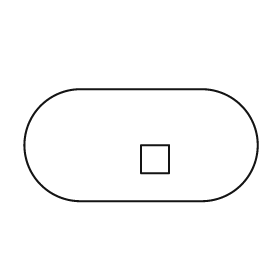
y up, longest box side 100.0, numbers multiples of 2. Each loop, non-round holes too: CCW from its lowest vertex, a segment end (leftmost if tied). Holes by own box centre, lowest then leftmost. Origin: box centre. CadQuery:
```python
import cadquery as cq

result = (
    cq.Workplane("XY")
    .moveTo(-26.0, -24.0)
    .lineTo(26.0, -24.0)
    .threePointArc((50.0, 0.0), (26.0, 24.0))
    .lineTo(-26.0, 24.0)
    .threePointArc((-50.0, 0.0), (-26.0, -24.0))
    .close()
    .moveTo(0.0, -12.0)
    .lineTo(12.0, -12.0)
    .lineTo(12.0, 0.0)
    .lineTo(0.0, 0.0)
    .close()
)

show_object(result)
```